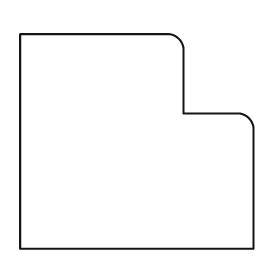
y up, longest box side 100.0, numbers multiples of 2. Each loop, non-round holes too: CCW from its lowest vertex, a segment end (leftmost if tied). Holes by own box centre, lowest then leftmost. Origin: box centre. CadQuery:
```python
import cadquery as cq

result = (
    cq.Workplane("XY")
    .moveTo(-50.0, -46.0)
    .lineTo(50.0, -46.0)
    .lineTo(50.0, 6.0)
    .threePointArc((48.0, 10.0), (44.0, 12.0))
    .lineTo(20.0, 12.0)
    .lineTo(20.0, 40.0)
    .threePointArc((18.0, 44.0), (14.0, 46.0))
    .lineTo(-50.0, 46.0)
    .close()
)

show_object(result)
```